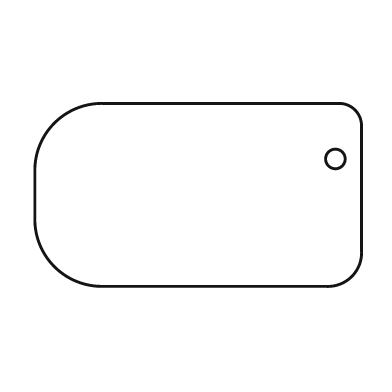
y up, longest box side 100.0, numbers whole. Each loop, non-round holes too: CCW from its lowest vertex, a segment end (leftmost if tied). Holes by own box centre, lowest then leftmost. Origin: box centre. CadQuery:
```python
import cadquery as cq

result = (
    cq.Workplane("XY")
    .moveTo(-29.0, -28.0)
    .lineTo(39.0, -28.0)
    .threePointArc((47.0, -25.0), (50.0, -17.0))
    .lineTo(50.0, 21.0)
    .threePointArc((48.0, 26.0), (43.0, 28.0))
    .lineTo(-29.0, 28.0)
    .threePointArc((-44.0, 22.0), (-50.0, 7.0))
    .lineTo(-50.0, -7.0)
    .threePointArc((-44.0, -22.0), (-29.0, -28.0))
    .close()
    .moveTo(42.0, 11.0)
    .circle(3.0)
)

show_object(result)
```